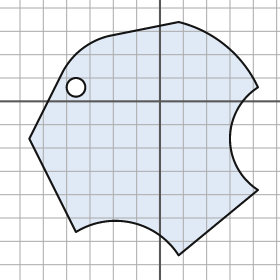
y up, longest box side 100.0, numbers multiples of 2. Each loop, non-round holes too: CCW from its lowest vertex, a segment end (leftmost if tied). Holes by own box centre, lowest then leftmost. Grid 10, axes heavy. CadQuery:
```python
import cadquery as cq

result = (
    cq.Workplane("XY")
    .moveTo(8.0, -66.0)
    .lineTo(42.0, -38.0)
    .threePointArc((30.0, -16.0), (42.0, 6.0))
    .threePointArc((28.0, 24.0), (8.0, 34.0))
    .lineTo(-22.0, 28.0)
    .threePointArc((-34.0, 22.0), (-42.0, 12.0))
    .lineTo(-56.0, -16.0)
    .lineTo(-36.0, -56.0)
    .threePointArc((-12.0, -52.0), (8.0, -66.0))
    .close()
    .moveTo(-36.0, 6.0)
    .circle(4.0)
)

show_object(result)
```